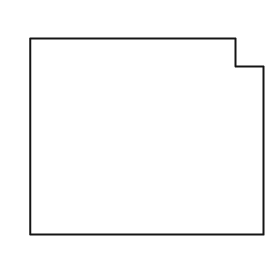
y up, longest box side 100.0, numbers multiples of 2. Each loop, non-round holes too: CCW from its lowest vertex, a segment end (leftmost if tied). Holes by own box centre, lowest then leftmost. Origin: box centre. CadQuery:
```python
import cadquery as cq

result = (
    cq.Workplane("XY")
    .moveTo(-50.0, -42.0)
    .lineTo(50.0, -42.0)
    .lineTo(50.0, 30.0)
    .lineTo(38.0, 30.0)
    .lineTo(38.0, 42.0)
    .lineTo(-50.0, 42.0)
    .close()
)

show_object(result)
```